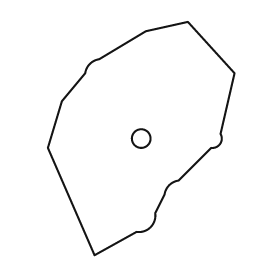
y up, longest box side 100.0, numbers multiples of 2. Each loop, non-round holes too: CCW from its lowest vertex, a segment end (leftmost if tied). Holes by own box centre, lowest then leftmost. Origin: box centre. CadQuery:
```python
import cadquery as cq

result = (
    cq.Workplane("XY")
    .moveTo(-20.0, -50.0)
    .lineTo(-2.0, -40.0)
    .threePointArc((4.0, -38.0), (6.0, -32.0))
    .lineTo(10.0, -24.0)
    .threePointArc((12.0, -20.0), (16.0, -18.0))
    .lineTo(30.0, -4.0)
    .threePointArc((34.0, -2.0), (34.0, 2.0))
    .lineTo(40.0, 28.0)
    .lineTo(20.0, 50.0)
    .lineTo(2.0, 46.0)
    .lineTo(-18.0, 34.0)
    .threePointArc((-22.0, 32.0), (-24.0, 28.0))
    .lineTo(-34.0, 16.0)
    .lineTo(-40.0, -4.0)
    .close()
    .moveTo(0.0, 0.0)
    .circle(4.0)
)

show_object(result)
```